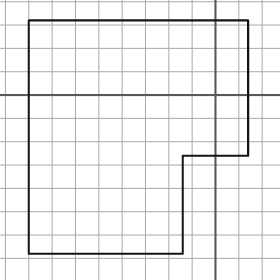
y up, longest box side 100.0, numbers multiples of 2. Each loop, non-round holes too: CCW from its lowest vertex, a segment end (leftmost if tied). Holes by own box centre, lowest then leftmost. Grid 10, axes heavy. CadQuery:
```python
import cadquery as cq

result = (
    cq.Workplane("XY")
    .moveTo(-80.0, -68.0)
    .lineTo(-14.0, -68.0)
    .lineTo(-14.0, -26.0)
    .lineTo(14.0, -26.0)
    .lineTo(14.0, 32.0)
    .lineTo(-80.0, 32.0)
    .close()
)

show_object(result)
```